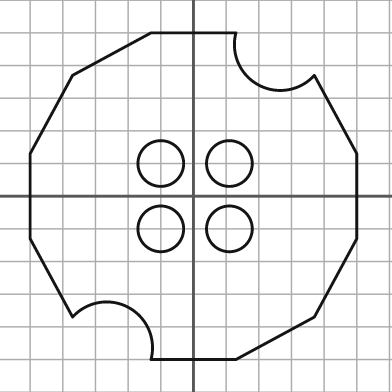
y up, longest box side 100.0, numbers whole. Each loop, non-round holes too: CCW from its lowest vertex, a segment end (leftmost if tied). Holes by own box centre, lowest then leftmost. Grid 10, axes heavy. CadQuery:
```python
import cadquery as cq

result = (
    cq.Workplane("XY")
    .moveTo(-13.0, -50.0)
    .lineTo(13.0, -50.0)
    .lineTo(37.0, -37.0)
    .lineTo(50.0, -13.0)
    .lineTo(50.0, 13.0)
    .lineTo(37.0, 37.0)
    .threePointArc((20.0, 34.0), (13.0, 50.0))
    .lineTo(-13.0, 50.0)
    .lineTo(-37.0, 37.0)
    .lineTo(-50.0, 13.0)
    .lineTo(-50.0, -13.0)
    .lineTo(-37.0, -37.0)
    .threePointArc((-20.0, -34.0), (-13.0, -50.0))
    .close()
    .moveTo(-10.0, -10.0)
    .circle(7.0)
    .moveTo(11.0, -10.0)
    .circle(7.0)
    .moveTo(-10.0, 10.0)
    .circle(7.0)
    .moveTo(11.0, 10.0)
    .circle(7.0)
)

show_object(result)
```